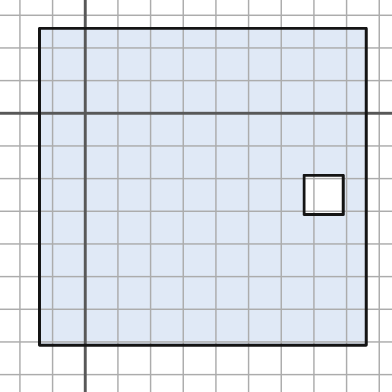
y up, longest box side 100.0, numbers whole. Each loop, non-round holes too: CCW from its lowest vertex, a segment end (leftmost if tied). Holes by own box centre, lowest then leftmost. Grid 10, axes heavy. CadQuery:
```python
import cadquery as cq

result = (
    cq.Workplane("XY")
    .moveTo(-14.0, -71.0)
    .lineTo(86.0, -71.0)
    .lineTo(86.0, 26.0)
    .lineTo(-14.0, 26.0)
    .close()
    .moveTo(67.0, -31.0)
    .lineTo(79.0, -31.0)
    .lineTo(79.0, -19.0)
    .lineTo(67.0, -19.0)
    .close()
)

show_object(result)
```